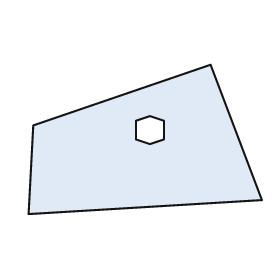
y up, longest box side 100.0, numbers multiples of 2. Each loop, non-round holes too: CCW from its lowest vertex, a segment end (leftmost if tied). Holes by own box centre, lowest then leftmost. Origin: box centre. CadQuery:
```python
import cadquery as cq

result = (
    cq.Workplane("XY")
    .moveTo(-50.0, -32.0)
    .lineTo(50.0, -26.0)
    .lineTo(28.0, 32.0)
    .lineTo(-48.0, 6.0)
    .close()
    .moveTo(2.0, -2.0)
    .lineTo(8.0, 0.0)
    .lineTo(8.0, 8.0)
    .lineTo(2.0, 10.0)
    .lineTo(-4.0, 8.0)
    .lineTo(-4.0, 0.0)
    .close()
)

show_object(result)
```